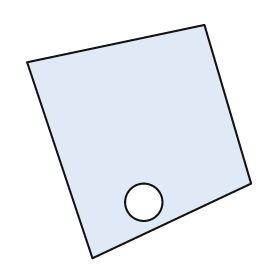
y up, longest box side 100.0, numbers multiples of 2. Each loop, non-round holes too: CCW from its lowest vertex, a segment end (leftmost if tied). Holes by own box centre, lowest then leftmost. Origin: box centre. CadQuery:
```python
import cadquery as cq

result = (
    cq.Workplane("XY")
    .moveTo(-20.0, -50.0)
    .lineTo(48.0, -18.0)
    .lineTo(28.0, 50.0)
    .lineTo(-48.0, 34.0)
    .close()
    .moveTo(2.0, -26.0)
    .circle(8.0)
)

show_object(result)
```